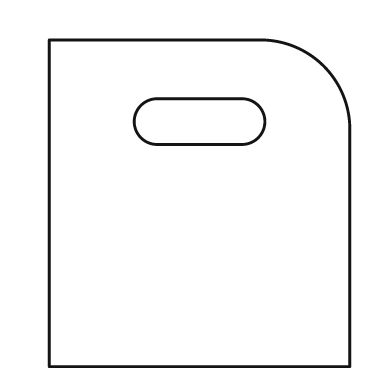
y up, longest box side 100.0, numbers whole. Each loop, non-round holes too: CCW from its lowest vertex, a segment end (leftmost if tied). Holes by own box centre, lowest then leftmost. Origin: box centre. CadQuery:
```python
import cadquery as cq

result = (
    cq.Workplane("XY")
    .moveTo(-46.0, -50.0)
    .lineTo(46.0, -50.0)
    .lineTo(46.0, 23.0)
    .threePointArc((38.0, 42.0), (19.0, 50.0))
    .lineTo(-46.0, 50.0)
    .close()
    .moveTo(-13.0, 18.0)
    .lineTo(13.0, 18.0)
    .threePointArc((20.0, 25.0), (13.0, 32.0))
    .lineTo(-13.0, 32.0)
    .threePointArc((-20.0, 25.0), (-13.0, 18.0))
    .close()
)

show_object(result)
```